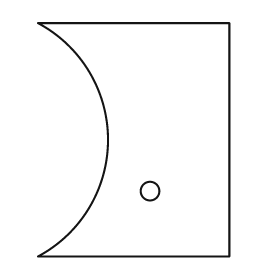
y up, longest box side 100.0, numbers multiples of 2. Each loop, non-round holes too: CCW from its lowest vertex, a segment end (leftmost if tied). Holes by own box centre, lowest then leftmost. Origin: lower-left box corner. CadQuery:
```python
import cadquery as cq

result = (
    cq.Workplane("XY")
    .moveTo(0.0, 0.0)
    .lineTo(82.0, 0.0)
    .lineTo(82.0, 100.0)
    .lineTo(0.0, 100.0)
    .threePointArc((30.0, 50.0), (0.0, 0.0))
    .close()
    .moveTo(48.0, 28.0)
    .circle(4.0)
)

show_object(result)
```